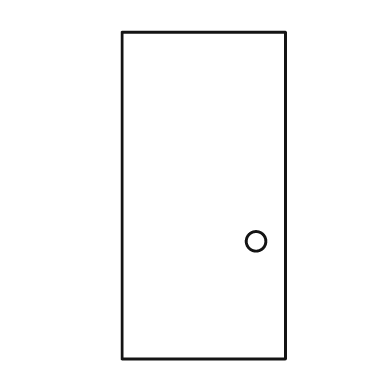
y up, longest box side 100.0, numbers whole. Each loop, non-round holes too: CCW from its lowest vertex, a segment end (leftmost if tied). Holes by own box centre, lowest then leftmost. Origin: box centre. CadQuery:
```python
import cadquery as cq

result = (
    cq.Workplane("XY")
    .moveTo(-25.0, -50.0)
    .lineTo(25.0, -50.0)
    .lineTo(25.0, 50.0)
    .lineTo(-25.0, 50.0)
    .close()
    .moveTo(16.0, -14.0)
    .circle(3.0)
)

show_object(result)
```